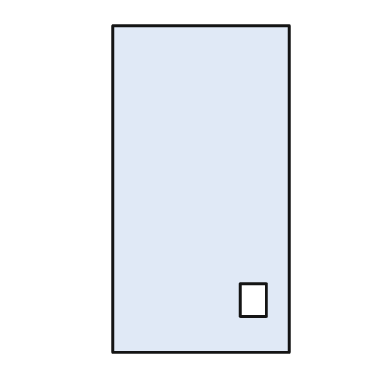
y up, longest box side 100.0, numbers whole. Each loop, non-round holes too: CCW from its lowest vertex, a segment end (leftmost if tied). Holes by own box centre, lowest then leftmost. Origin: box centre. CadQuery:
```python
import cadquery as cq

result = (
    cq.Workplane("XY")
    .moveTo(-27.0, -50.0)
    .lineTo(27.0, -50.0)
    .lineTo(27.0, 50.0)
    .lineTo(-27.0, 50.0)
    .close()
    .moveTo(12.0, -39.0)
    .lineTo(20.0, -39.0)
    .lineTo(20.0, -29.0)
    .lineTo(12.0, -29.0)
    .close()
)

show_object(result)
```